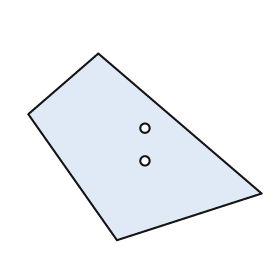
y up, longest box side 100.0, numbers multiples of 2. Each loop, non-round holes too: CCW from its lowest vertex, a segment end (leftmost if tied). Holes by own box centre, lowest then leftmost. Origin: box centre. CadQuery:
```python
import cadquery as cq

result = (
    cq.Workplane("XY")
    .moveTo(-12.0, -40.0)
    .lineTo(50.0, -20.0)
    .lineTo(-20.0, 40.0)
    .lineTo(-50.0, 14.0)
    .close()
    .moveTo(0.0, -6.0)
    .circle(2.0)
    .moveTo(0.0, 8.0)
    .circle(2.0)
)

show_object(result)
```